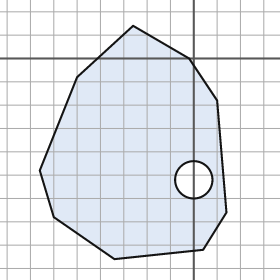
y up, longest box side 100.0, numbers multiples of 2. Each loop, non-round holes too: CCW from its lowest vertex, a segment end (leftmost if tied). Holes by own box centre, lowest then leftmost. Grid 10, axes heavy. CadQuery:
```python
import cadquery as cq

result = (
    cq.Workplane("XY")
    .moveTo(-34.0, -86.0)
    .lineTo(4.0, -82.0)
    .lineTo(14.0, -66.0)
    .lineTo(10.0, -18.0)
    .lineTo(-2.0, 0.0)
    .lineTo(-26.0, 14.0)
    .lineTo(-50.0, -8.0)
    .lineTo(-66.0, -48.0)
    .lineTo(-60.0, -68.0)
    .close()
    .moveTo(0.0, -52.0)
    .circle(8.0)
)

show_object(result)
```